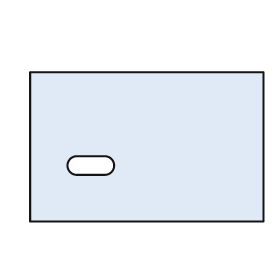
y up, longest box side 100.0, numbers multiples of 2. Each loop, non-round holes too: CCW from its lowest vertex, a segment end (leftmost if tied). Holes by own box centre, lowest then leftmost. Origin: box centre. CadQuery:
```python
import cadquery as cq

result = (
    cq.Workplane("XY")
    .moveTo(-50.0, -32.0)
    .lineTo(50.0, -32.0)
    .lineTo(50.0, 32.0)
    .lineTo(-50.0, 32.0)
    .close()
    .moveTo(-30.0, -12.0)
    .lineTo(-18.0, -12.0)
    .threePointArc((-14.0, -8.0), (-18.0, -4.0))
    .lineTo(-30.0, -4.0)
    .threePointArc((-34.0, -8.0), (-30.0, -12.0))
    .close()
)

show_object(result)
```